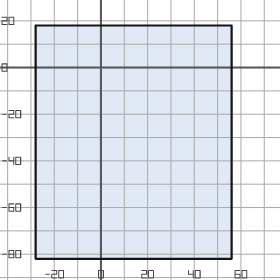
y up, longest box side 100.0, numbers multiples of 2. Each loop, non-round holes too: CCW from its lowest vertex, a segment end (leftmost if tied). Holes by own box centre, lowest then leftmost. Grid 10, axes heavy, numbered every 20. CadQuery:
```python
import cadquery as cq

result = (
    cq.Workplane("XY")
    .moveTo(-28.0, -82.0)
    .lineTo(56.0, -82.0)
    .lineTo(56.0, 18.0)
    .lineTo(-28.0, 18.0)
    .close()
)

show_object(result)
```